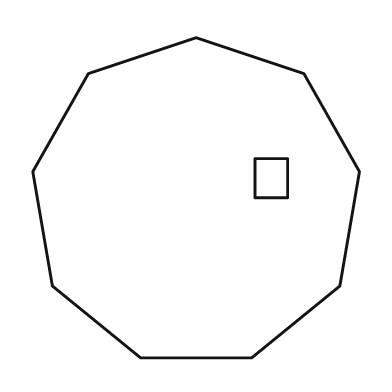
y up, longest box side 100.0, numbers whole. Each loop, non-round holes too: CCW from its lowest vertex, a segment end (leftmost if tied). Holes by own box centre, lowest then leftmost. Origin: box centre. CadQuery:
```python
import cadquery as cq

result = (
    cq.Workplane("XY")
    .moveTo(-17.0, -49.0)
    .lineTo(17.0, -49.0)
    .lineTo(44.0, -27.0)
    .lineTo(50.0, 8.0)
    .lineTo(33.0, 38.0)
    .lineTo(0.0, 49.0)
    .lineTo(-33.0, 38.0)
    .lineTo(-50.0, 8.0)
    .lineTo(-44.0, -27.0)
    .close()
    .moveTo(18.0, 0.0)
    .lineTo(28.0, 0.0)
    .lineTo(28.0, 12.0)
    .lineTo(18.0, 12.0)
    .close()
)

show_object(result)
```